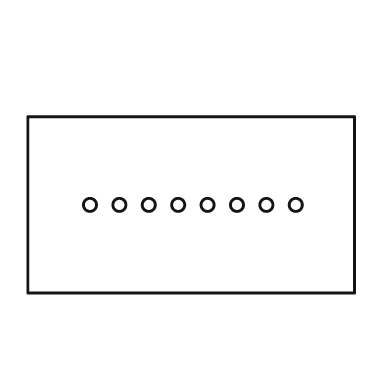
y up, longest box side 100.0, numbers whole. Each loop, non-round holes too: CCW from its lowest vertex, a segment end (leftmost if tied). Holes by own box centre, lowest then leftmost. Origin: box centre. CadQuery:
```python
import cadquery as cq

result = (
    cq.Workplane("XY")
    .moveTo(-50.0, -27.0)
    .lineTo(50.0, -27.0)
    .lineTo(50.0, 27.0)
    .lineTo(-50.0, 27.0)
    .close()
    .moveTo(-31.0, 0.0)
    .circle(2.0)
    .moveTo(-22.0, 0.0)
    .circle(2.0)
    .moveTo(-13.0, 0.0)
    .circle(2.0)
    .moveTo(-4.0, 0.0)
    .circle(2.0)
    .moveTo(5.0, 0.0)
    .circle(2.0)
    .moveTo(14.0, 0.0)
    .circle(2.0)
    .moveTo(23.0, 0.0)
    .circle(2.0)
    .moveTo(32.0, 0.0)
    .circle(2.0)
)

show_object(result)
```